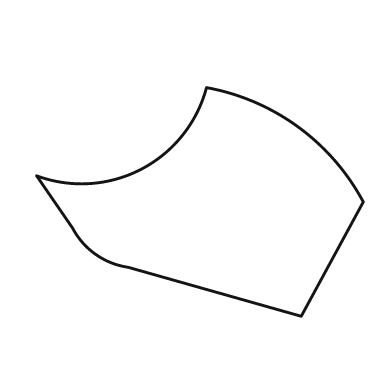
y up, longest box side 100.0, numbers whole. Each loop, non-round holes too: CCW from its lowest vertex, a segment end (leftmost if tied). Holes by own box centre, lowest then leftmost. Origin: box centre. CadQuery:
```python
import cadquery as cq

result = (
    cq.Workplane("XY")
    .moveTo(31.0, -35.0)
    .lineTo(50.0, 0.0)
    .threePointArc((30.0, 23.0), (2.0, 35.0))
    .threePointArc((-18.0, 10.0), (-50.0, 8.0))
    .lineTo(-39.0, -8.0)
    .threePointArc((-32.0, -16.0), (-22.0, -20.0))
    .close()
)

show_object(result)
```